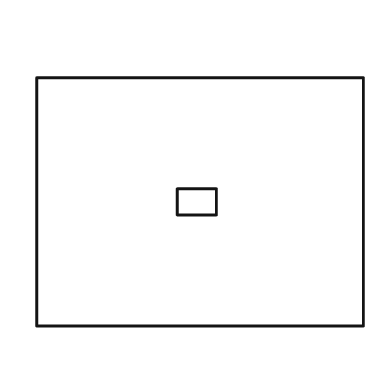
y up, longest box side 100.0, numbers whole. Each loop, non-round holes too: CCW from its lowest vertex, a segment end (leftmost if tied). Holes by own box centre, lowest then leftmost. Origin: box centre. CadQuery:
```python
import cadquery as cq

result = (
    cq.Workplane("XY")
    .moveTo(-50.0, -38.0)
    .lineTo(50.0, -38.0)
    .lineTo(50.0, 38.0)
    .lineTo(-50.0, 38.0)
    .close()
    .moveTo(-7.0, -4.0)
    .lineTo(5.0, -4.0)
    .lineTo(5.0, 4.0)
    .lineTo(-7.0, 4.0)
    .close()
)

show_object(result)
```